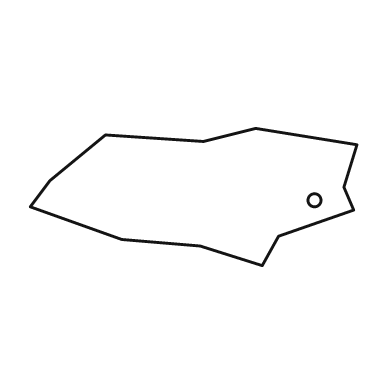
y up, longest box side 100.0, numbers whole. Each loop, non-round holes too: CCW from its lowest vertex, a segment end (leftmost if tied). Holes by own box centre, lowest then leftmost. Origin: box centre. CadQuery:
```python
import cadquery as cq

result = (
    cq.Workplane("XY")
    .moveTo(21.0, -21.0)
    .lineTo(26.0, -12.0)
    .lineTo(49.0, -4.0)
    .lineTo(46.0, 3.0)
    .lineTo(50.0, 16.0)
    .lineTo(19.0, 21.0)
    .lineTo(3.0, 17.0)
    .lineTo(-27.0, 19.0)
    .lineTo(-44.0, 5.0)
    .lineTo(-50.0, -3.0)
    .lineTo(-22.0, -13.0)
    .lineTo(2.0, -15.0)
    .close()
    .moveTo(37.0, -1.0)
    .circle(2.0)
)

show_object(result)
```